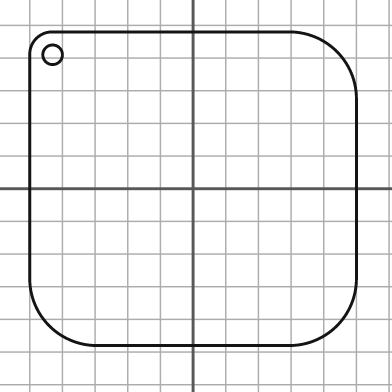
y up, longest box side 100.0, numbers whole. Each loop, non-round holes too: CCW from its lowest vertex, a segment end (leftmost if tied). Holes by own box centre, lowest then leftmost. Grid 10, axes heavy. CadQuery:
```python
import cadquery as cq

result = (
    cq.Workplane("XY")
    .moveTo(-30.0, -48.0)
    .lineTo(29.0, -48.0)
    .threePointArc((44.0, -42.0), (50.0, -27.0))
    .lineTo(50.0, 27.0)
    .threePointArc((44.0, 42.0), (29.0, 48.0))
    .lineTo(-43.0, 48.0)
    .threePointArc((-48.0, 46.0), (-50.0, 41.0))
    .lineTo(-50.0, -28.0)
    .threePointArc((-44.0, -42.0), (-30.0, -48.0))
    .close()
    .moveTo(-43.0, 41.0)
    .circle(3.0)
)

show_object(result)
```